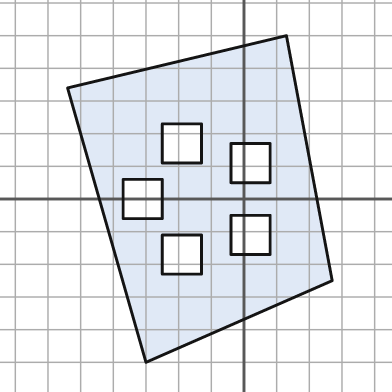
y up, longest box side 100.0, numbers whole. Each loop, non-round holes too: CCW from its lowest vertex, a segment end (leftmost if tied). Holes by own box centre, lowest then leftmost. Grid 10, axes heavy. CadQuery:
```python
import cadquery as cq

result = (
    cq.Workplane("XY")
    .moveTo(-30.0, -50.0)
    .lineTo(27.0, -25.0)
    .lineTo(13.0, 50.0)
    .lineTo(-54.0, 34.0)
    .close()
    .moveTo(-25.0, -23.0)
    .lineTo(-13.0, -23.0)
    .lineTo(-13.0, -11.0)
    .lineTo(-25.0, -11.0)
    .close()
    .moveTo(-4.0, -17.0)
    .lineTo(8.0, -17.0)
    .lineTo(8.0, -5.0)
    .lineTo(-4.0, -5.0)
    .close()
    .moveTo(-37.0, -6.0)
    .lineTo(-25.0, -6.0)
    .lineTo(-25.0, 6.0)
    .lineTo(-37.0, 6.0)
    .close()
    .moveTo(-4.0, 5.0)
    .lineTo(8.0, 5.0)
    .lineTo(8.0, 17.0)
    .lineTo(-4.0, 17.0)
    .close()
    .moveTo(-25.0, 11.0)
    .lineTo(-13.0, 11.0)
    .lineTo(-13.0, 23.0)
    .lineTo(-25.0, 23.0)
    .close()
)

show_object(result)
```